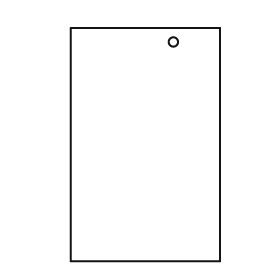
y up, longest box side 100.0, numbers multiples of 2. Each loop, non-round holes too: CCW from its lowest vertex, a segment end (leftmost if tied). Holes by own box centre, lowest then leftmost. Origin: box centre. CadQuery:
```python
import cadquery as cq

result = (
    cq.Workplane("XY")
    .moveTo(-32.0, -50.0)
    .lineTo(32.0, -50.0)
    .lineTo(32.0, 50.0)
    .lineTo(-32.0, 50.0)
    .close()
    .moveTo(12.0, 44.0)
    .circle(2.0)
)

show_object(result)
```